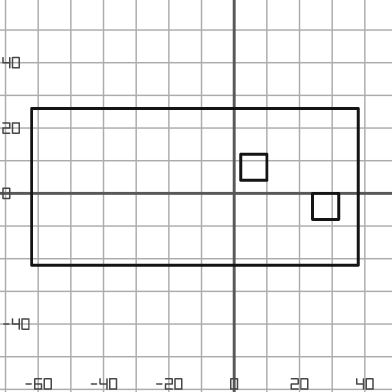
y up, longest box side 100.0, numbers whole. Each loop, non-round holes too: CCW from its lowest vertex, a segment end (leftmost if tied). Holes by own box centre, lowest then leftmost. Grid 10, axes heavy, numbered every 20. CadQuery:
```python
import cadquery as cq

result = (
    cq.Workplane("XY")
    .moveTo(-62.0, -22.0)
    .lineTo(38.0, -22.0)
    .lineTo(38.0, 26.0)
    .lineTo(-62.0, 26.0)
    .close()
    .moveTo(24.0, -8.0)
    .lineTo(32.0, -8.0)
    .lineTo(32.0, 0.0)
    .lineTo(24.0, 0.0)
    .close()
    .moveTo(2.0, 4.0)
    .lineTo(10.0, 4.0)
    .lineTo(10.0, 12.0)
    .lineTo(2.0, 12.0)
    .close()
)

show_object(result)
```